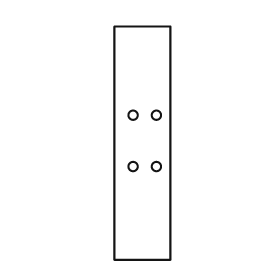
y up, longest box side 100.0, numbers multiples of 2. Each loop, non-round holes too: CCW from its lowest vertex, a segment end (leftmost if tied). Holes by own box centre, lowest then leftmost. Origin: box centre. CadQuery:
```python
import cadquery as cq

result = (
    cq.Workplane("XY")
    .moveTo(-12.0, -50.0)
    .lineTo(12.0, -50.0)
    .lineTo(12.0, 50.0)
    .lineTo(-12.0, 50.0)
    .close()
    .moveTo(-4.0, -10.0)
    .circle(2.0)
    .moveTo(6.0, -10.0)
    .circle(2.0)
    .moveTo(-4.0, 12.0)
    .circle(2.0)
    .moveTo(6.0, 12.0)
    .circle(2.0)
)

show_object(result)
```